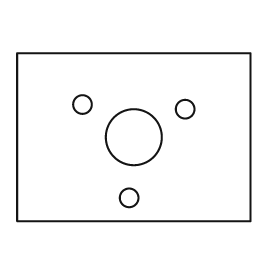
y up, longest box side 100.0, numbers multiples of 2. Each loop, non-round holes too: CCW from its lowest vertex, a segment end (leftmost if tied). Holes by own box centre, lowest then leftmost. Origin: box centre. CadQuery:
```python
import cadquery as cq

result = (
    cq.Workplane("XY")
    .moveTo(-50.0, -36.0)
    .lineTo(50.0, -36.0)
    .lineTo(50.0, 36.0)
    .lineTo(-50.0, 36.0)
    .close()
    .moveTo(-2.0, -26.0)
    .circle(4.0)
    .moveTo(0.0, 0.0)
    .circle(12.0)
    .moveTo(22.0, 12.0)
    .circle(4.0)
    .moveTo(-22.0, 14.0)
    .circle(4.0)
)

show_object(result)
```